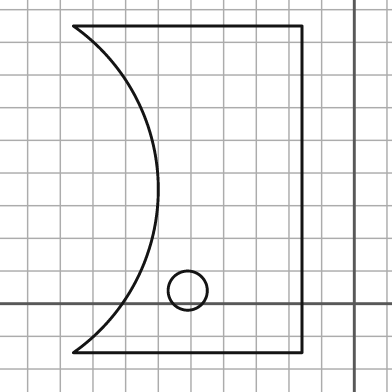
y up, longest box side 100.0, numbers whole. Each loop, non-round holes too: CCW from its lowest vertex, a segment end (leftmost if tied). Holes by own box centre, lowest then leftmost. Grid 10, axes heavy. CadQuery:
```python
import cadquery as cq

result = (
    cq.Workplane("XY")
    .moveTo(-86.0, -15.0)
    .lineTo(-16.0, -15.0)
    .lineTo(-16.0, 85.0)
    .lineTo(-86.0, 85.0)
    .threePointArc((-60.0, 35.0), (-86.0, -15.0))
    .close()
    .moveTo(-51.0, 4.0)
    .circle(6.0)
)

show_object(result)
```